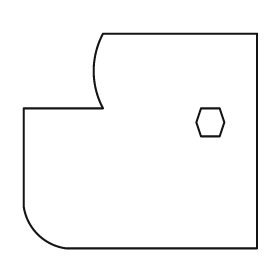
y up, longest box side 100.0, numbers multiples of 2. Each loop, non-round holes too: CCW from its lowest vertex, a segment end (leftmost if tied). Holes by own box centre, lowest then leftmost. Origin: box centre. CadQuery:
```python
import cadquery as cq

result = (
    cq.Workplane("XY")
    .moveTo(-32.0, -46.0)
    .lineTo(50.0, -46.0)
    .lineTo(50.0, 46.0)
    .lineTo(-16.0, 46.0)
    .threePointArc((-20.0, 30.0), (-16.0, 14.0))
    .lineTo(-50.0, 14.0)
    .lineTo(-50.0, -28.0)
    .threePointArc((-44.0, -40.0), (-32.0, -46.0))
    .close()
    .moveTo(26.0, 2.0)
    .lineTo(34.0, 2.0)
    .lineTo(36.0, 8.0)
    .lineTo(34.0, 14.0)
    .lineTo(26.0, 14.0)
    .lineTo(24.0, 8.0)
    .close()
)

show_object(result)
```